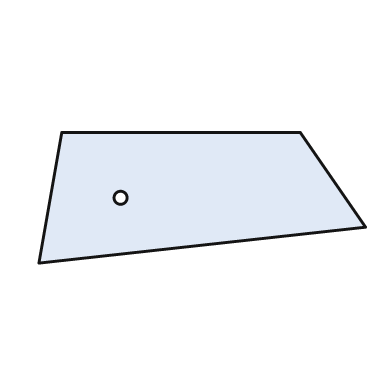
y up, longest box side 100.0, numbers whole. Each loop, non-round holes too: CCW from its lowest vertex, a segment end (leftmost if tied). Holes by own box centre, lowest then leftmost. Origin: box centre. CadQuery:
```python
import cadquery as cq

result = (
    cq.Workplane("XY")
    .moveTo(-50.0, -20.0)
    .lineTo(50.0, -9.0)
    .lineTo(30.0, 20.0)
    .lineTo(-43.0, 20.0)
    .close()
    .moveTo(-25.0, 0.0)
    .circle(2.0)
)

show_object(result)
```